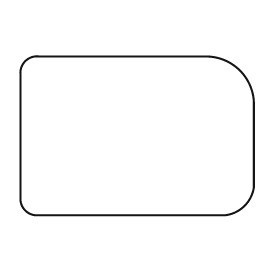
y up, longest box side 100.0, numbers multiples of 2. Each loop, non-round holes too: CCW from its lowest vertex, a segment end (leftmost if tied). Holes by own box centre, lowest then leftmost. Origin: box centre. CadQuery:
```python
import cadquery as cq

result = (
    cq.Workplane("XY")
    .moveTo(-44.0, -34.0)
    .lineTo(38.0, -34.0)
    .threePointArc((46.0, -30.0), (50.0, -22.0))
    .lineTo(50.0, 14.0)
    .threePointArc((44.0, 28.0), (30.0, 34.0))
    .lineTo(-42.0, 34.0)
    .threePointArc((-48.0, 32.0), (-50.0, 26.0))
    .lineTo(-50.0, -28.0)
    .threePointArc((-48.0, -32.0), (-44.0, -34.0))
    .close()
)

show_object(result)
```